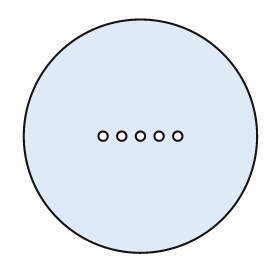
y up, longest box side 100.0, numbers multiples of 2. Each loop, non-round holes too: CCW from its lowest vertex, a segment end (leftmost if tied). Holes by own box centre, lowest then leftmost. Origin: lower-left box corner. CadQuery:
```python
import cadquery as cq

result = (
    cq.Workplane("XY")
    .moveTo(50.0, 50.0)
    .circle(50.0)
    .moveTo(34.0, 50.0)
    .circle(2.0)
    .moveTo(42.0, 50.0)
    .circle(2.0)
    .moveTo(50.0, 50.0)
    .circle(2.0)
    .moveTo(58.0, 50.0)
    .circle(2.0)
    .moveTo(66.0, 50.0)
    .circle(2.0)
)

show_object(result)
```